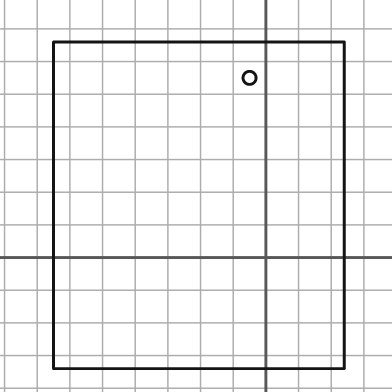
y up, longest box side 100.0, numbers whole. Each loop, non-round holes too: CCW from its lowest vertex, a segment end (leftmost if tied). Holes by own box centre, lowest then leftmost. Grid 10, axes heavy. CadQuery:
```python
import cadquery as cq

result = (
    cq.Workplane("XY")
    .moveTo(-65.0, -34.0)
    .lineTo(24.0, -34.0)
    .lineTo(24.0, 66.0)
    .lineTo(-65.0, 66.0)
    .close()
    .moveTo(-5.0, 55.0)
    .circle(2.0)
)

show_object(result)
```